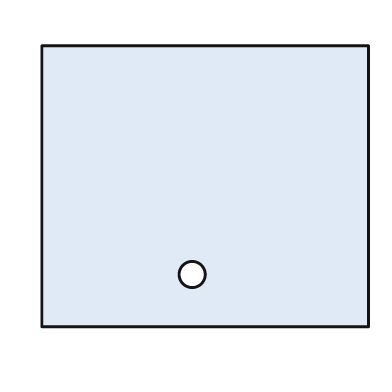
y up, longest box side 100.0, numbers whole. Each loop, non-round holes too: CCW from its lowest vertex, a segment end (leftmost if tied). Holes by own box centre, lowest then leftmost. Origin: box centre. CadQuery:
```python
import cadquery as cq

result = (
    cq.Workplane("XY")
    .moveTo(-50.0, -43.0)
    .lineTo(50.0, -43.0)
    .lineTo(50.0, 43.0)
    .lineTo(-50.0, 43.0)
    .close()
    .moveTo(-4.0, -27.0)
    .circle(4.0)
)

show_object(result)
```